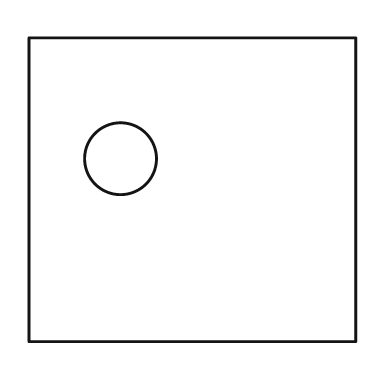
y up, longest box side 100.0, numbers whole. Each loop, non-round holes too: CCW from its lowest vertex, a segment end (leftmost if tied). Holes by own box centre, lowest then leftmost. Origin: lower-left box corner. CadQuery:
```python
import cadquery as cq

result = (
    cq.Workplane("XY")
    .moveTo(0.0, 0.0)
    .lineTo(100.0, 0.0)
    .lineTo(100.0, 93.0)
    .lineTo(0.0, 93.0)
    .close()
    .moveTo(28.0, 56.0)
    .circle(11.0)
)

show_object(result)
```